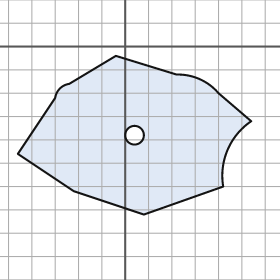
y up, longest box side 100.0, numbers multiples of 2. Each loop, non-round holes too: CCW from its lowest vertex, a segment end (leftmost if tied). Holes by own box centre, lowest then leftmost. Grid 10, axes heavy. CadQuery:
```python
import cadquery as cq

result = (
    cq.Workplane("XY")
    .moveTo(8.0, -72.0)
    .lineTo(42.0, -60.0)
    .threePointArc((44.0, -44.0), (54.0, -32.0))
    .lineTo(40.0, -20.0)
    .threePointArc((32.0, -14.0), (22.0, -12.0))
    .lineTo(-4.0, -4.0)
    .lineTo(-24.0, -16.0)
    .threePointArc((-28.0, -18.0), (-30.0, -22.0))
    .lineTo(-46.0, -46.0)
    .lineTo(-22.0, -62.0)
    .close()
    .moveTo(4.0, -38.0)
    .circle(4.0)
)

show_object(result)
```